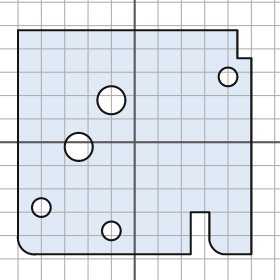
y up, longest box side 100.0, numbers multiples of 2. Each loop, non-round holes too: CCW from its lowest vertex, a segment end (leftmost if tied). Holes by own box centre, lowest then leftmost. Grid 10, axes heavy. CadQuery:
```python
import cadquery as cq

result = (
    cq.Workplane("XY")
    .moveTo(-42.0, -48.0)
    .lineTo(24.0, -48.0)
    .lineTo(24.0, -30.0)
    .lineTo(32.0, -30.0)
    .lineTo(32.0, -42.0)
    .threePointArc((34.0, -46.0), (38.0, -48.0))
    .lineTo(50.0, -48.0)
    .lineTo(50.0, 36.0)
    .lineTo(44.0, 36.0)
    .lineTo(44.0, 48.0)
    .lineTo(-50.0, 48.0)
    .lineTo(-50.0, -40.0)
    .threePointArc((-48.0, -46.0), (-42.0, -48.0))
    .close()
    .moveTo(-10.0, -38.0)
    .circle(4.0)
    .moveTo(-40.0, -28.0)
    .circle(4.0)
    .moveTo(-24.0, -2.0)
    .circle(6.0)
    .moveTo(-10.0, 18.0)
    .circle(6.0)
    .moveTo(40.0, 28.0)
    .circle(4.0)
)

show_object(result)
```